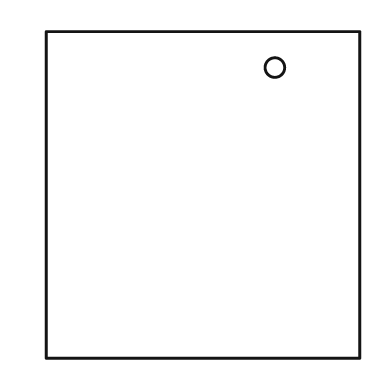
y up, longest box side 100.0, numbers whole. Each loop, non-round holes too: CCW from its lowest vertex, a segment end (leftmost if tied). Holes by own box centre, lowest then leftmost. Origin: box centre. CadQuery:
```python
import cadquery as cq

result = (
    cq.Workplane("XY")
    .moveTo(-48.0, -50.0)
    .lineTo(48.0, -50.0)
    .lineTo(48.0, 50.0)
    .lineTo(-48.0, 50.0)
    .close()
    .moveTo(22.0, 39.0)
    .circle(3.0)
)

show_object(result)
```